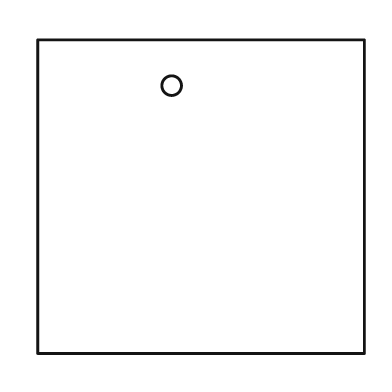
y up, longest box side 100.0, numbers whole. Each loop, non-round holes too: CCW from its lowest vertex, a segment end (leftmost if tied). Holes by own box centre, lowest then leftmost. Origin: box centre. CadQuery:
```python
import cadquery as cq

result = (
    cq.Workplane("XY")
    .moveTo(-50.0, -48.0)
    .lineTo(50.0, -48.0)
    .lineTo(50.0, 48.0)
    .lineTo(-50.0, 48.0)
    .close()
    .moveTo(-9.0, 34.0)
    .circle(3.0)
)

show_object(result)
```